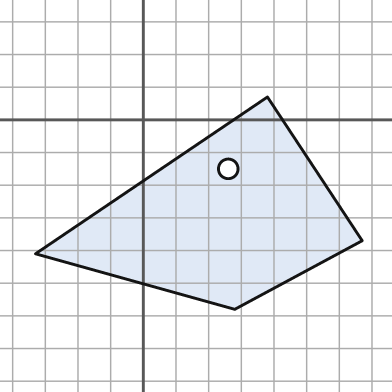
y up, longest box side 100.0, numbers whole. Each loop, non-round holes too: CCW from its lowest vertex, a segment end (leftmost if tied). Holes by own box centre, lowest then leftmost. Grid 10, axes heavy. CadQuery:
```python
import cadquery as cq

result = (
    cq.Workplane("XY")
    .moveTo(28.0, -58.0)
    .lineTo(67.0, -37.0)
    .lineTo(38.0, 7.0)
    .lineTo(-33.0, -41.0)
    .close()
    .moveTo(26.0, -15.0)
    .circle(3.0)
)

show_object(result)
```